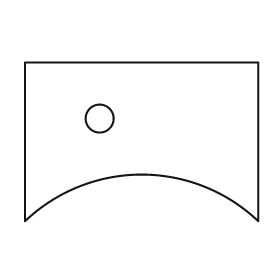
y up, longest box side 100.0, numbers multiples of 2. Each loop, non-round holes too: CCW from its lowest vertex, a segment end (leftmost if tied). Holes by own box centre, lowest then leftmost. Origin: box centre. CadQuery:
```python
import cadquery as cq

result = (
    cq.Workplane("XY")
    .moveTo(-50.0, -34.0)
    .threePointArc((0.0, -14.0), (50.0, -34.0))
    .lineTo(50.0, 34.0)
    .lineTo(-50.0, 34.0)
    .close()
    .moveTo(-18.0, 10.0)
    .circle(6.0)
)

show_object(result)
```